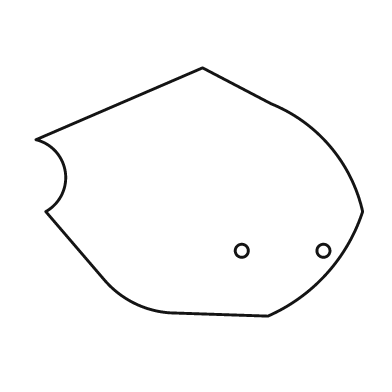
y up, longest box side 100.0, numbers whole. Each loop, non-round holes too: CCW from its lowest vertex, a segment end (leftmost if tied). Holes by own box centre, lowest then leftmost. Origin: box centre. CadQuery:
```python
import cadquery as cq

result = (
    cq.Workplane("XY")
    .moveTo(21.0, -38.0)
    .threePointArc((39.0, -25.0), (50.0, -6.0))
    .threePointArc((40.0, 14.0), (22.0, 27.0))
    .lineTo(1.0, 38.0)
    .lineTo(-50.0, 16.0)
    .threePointArc((-41.0, 6.0), (-47.0, -6.0))
    .lineTo(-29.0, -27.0)
    .threePointArc((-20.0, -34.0), (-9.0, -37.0))
    .close()
    .moveTo(13.0, -18.0)
    .circle(2.0)
    .moveTo(38.0, -18.0)
    .circle(2.0)
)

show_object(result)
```